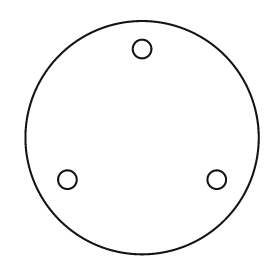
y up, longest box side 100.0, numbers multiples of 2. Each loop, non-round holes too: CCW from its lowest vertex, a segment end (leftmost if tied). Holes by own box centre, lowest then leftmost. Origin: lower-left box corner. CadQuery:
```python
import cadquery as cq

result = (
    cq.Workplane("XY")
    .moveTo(50.0, 50.0)
    .circle(50.0)
    .moveTo(18.0, 32.0)
    .circle(4.0)
    .moveTo(82.0, 32.0)
    .circle(4.0)
    .moveTo(50.0, 88.0)
    .circle(4.0)
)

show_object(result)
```